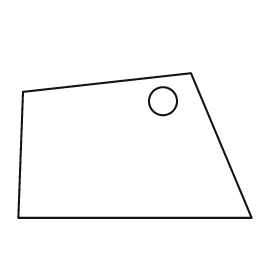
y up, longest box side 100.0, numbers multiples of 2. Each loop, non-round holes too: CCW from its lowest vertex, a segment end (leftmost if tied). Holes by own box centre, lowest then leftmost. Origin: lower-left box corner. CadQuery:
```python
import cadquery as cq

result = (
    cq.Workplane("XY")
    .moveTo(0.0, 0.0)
    .lineTo(100.0, 0.0)
    .lineTo(74.0, 62.0)
    .lineTo(2.0, 54.0)
    .close()
    .moveTo(62.0, 50.0)
    .circle(6.0)
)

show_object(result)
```